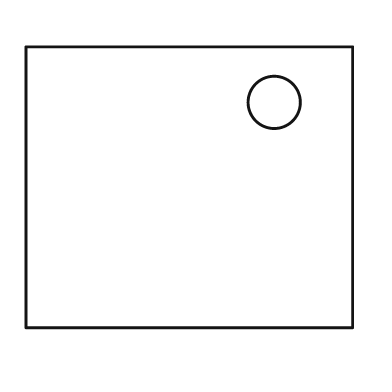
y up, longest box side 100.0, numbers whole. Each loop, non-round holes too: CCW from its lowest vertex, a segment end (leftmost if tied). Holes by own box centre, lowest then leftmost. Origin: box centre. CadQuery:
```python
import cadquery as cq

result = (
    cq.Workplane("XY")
    .moveTo(-50.0, -43.0)
    .lineTo(50.0, -43.0)
    .lineTo(50.0, 43.0)
    .lineTo(-50.0, 43.0)
    .close()
    .moveTo(26.0, 26.0)
    .circle(8.0)
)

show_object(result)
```